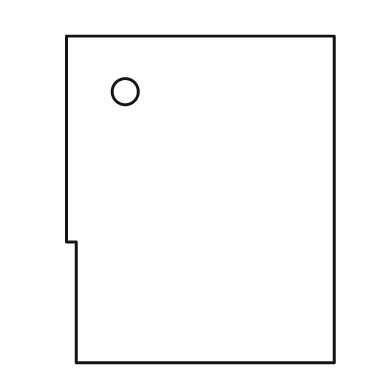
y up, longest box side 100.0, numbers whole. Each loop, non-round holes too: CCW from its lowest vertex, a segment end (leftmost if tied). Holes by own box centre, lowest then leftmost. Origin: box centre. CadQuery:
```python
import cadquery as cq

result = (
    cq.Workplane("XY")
    .moveTo(-38.0, -50.0)
    .lineTo(41.0, -50.0)
    .lineTo(41.0, 50.0)
    .lineTo(-41.0, 50.0)
    .lineTo(-41.0, -13.0)
    .lineTo(-38.0, -13.0)
    .close()
    .moveTo(-23.0, 33.0)
    .circle(4.0)
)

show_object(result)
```